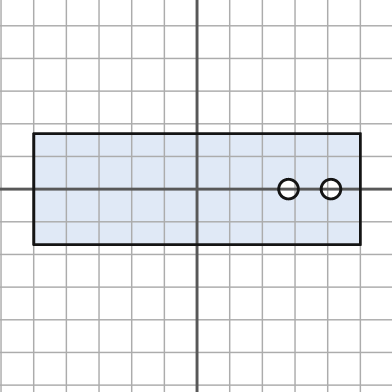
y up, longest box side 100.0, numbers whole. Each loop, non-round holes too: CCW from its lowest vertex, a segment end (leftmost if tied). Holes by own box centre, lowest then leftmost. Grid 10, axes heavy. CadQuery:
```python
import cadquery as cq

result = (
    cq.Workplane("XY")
    .moveTo(-50.0, -17.0)
    .lineTo(50.0, -17.0)
    .lineTo(50.0, 17.0)
    .lineTo(-50.0, 17.0)
    .close()
    .moveTo(28.0, 0.0)
    .circle(3.0)
    .moveTo(41.0, 0.0)
    .circle(3.0)
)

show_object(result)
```